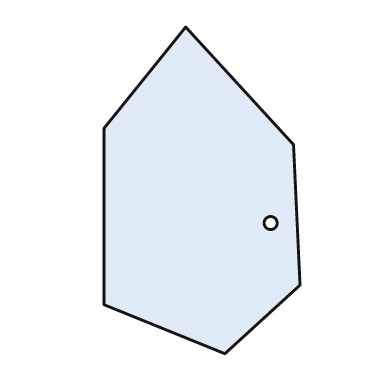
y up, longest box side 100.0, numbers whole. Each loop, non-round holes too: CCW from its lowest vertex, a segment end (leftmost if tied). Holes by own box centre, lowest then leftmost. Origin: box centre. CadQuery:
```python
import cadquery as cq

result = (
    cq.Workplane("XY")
    .moveTo(7.0, -50.0)
    .lineTo(30.0, -29.0)
    .lineTo(28.0, 14.0)
    .lineTo(-5.0, 50.0)
    .lineTo(-30.0, 19.0)
    .lineTo(-30.0, -35.0)
    .close()
    .moveTo(21.0, -10.0)
    .circle(2.0)
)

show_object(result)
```